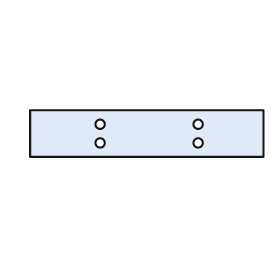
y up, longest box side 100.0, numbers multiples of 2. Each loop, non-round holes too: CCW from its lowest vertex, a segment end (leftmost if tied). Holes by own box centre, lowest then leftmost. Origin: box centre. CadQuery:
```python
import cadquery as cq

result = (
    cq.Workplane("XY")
    .moveTo(-50.0, -10.0)
    .lineTo(50.0, -10.0)
    .lineTo(50.0, 10.0)
    .lineTo(-50.0, 10.0)
    .close()
    .moveTo(-20.0, -4.0)
    .circle(2.0)
    .moveTo(22.0, -4.0)
    .circle(2.0)
    .moveTo(-20.0, 4.0)
    .circle(2.0)
    .moveTo(22.0, 4.0)
    .circle(2.0)
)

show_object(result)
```